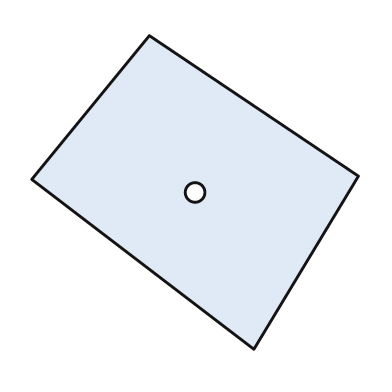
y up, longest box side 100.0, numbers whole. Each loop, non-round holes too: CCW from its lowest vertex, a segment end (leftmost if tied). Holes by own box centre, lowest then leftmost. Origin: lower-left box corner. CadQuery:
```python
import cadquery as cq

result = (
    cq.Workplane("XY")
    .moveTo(68.0, 0.0)
    .lineTo(100.0, 53.0)
    .lineTo(36.0, 96.0)
    .lineTo(0.0, 52.0)
    .close()
    .moveTo(50.0, 48.0)
    .circle(3.0)
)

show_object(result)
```